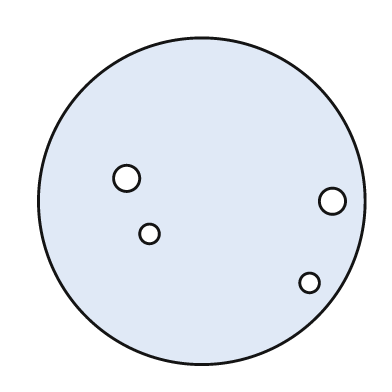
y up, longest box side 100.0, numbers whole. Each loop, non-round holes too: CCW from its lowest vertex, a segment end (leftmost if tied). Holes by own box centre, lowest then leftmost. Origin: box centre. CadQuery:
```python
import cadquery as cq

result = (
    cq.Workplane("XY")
    .moveTo(0.0, 0.0)
    .circle(50.0)
    .moveTo(33.0, -25.0)
    .circle(3.0)
    .moveTo(-16.0, -10.0)
    .circle(3.0)
    .moveTo(40.0, 0.0)
    .circle(4.0)
    .moveTo(-23.0, 7.0)
    .circle(4.0)
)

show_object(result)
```